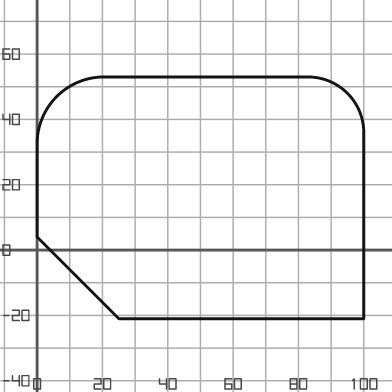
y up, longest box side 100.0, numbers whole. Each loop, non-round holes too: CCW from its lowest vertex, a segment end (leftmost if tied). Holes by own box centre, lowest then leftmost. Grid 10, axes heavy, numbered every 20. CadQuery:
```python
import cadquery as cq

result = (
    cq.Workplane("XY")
    .moveTo(25.0, -21.0)
    .lineTo(100.0, -21.0)
    .lineTo(100.0, 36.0)
    .threePointArc((95.0, 48.0), (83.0, 53.0))
    .lineTo(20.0, 53.0)
    .threePointArc((6.0, 47.0), (0.0, 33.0))
    .lineTo(0.0, 4.0)
    .close()
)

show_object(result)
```